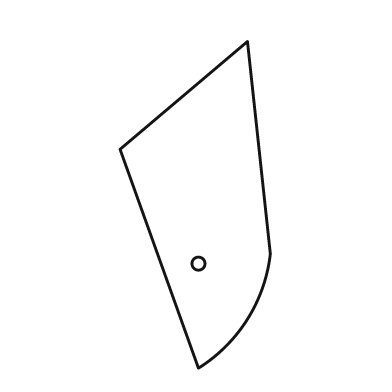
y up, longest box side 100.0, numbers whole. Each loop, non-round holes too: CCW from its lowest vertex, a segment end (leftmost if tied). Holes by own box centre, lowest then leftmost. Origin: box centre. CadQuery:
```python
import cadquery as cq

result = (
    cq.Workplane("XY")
    .moveTo(1.0, -50.0)
    .threePointArc((16.0, -35.0), (23.0, -15.0))
    .lineTo(16.0, 50.0)
    .lineTo(-23.0, 17.0)
    .close()
    .moveTo(1.0, -18.0)
    .circle(2.0)
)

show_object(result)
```